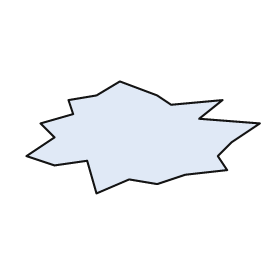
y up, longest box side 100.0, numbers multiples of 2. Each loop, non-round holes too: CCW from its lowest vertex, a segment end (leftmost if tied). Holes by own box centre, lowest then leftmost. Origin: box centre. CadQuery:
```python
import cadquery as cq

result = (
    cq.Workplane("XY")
    .moveTo(-20.0, -24.0)
    .lineTo(-6.0, -18.0)
    .lineTo(6.0, -20.0)
    .lineTo(18.0, -16.0)
    .lineTo(36.0, -14.0)
    .lineTo(32.0, -8.0)
    .lineTo(38.0, -2.0)
    .lineTo(50.0, 6.0)
    .lineTo(24.0, 8.0)
    .lineTo(34.0, 16.0)
    .lineTo(12.0, 14.0)
    .lineTo(6.0, 18.0)
    .lineTo(-10.0, 24.0)
    .lineTo(-20.0, 18.0)
    .lineTo(-32.0, 16.0)
    .lineTo(-30.0, 10.0)
    .lineTo(-44.0, 6.0)
    .lineTo(-38.0, 0.0)
    .lineTo(-50.0, -8.0)
    .lineTo(-38.0, -12.0)
    .lineTo(-24.0, -10.0)
    .close()
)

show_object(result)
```